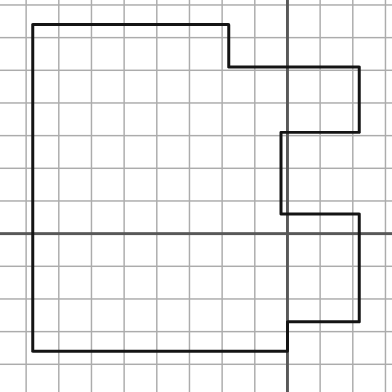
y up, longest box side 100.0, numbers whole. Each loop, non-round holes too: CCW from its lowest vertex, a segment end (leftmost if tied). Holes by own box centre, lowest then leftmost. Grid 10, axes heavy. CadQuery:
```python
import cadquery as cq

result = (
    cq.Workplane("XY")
    .moveTo(-78.0, -36.0)
    .lineTo(0.0, -36.0)
    .lineTo(0.0, -27.0)
    .lineTo(22.0, -27.0)
    .lineTo(22.0, 6.0)
    .lineTo(-2.0, 6.0)
    .lineTo(-2.0, 31.0)
    .lineTo(22.0, 31.0)
    .lineTo(22.0, 51.0)
    .lineTo(-18.0, 51.0)
    .lineTo(-18.0, 64.0)
    .lineTo(-78.0, 64.0)
    .close()
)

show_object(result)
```